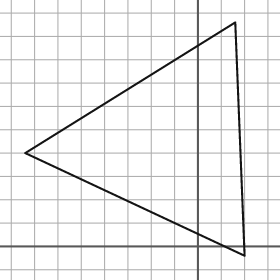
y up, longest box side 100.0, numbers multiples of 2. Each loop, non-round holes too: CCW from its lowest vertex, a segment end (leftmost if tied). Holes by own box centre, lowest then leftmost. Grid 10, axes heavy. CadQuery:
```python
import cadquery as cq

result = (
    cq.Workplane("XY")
    .moveTo(20.0, -4.0)
    .lineTo(16.0, 96.0)
    .lineTo(-74.0, 40.0)
    .close()
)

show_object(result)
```